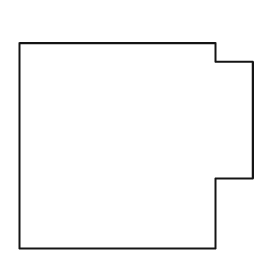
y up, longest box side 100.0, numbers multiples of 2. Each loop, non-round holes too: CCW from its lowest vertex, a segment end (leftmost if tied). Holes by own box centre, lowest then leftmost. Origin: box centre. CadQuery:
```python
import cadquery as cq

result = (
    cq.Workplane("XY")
    .moveTo(-50.0, -44.0)
    .lineTo(34.0, -44.0)
    .lineTo(34.0, -14.0)
    .lineTo(50.0, -14.0)
    .lineTo(50.0, 36.0)
    .lineTo(34.0, 36.0)
    .lineTo(34.0, 44.0)
    .lineTo(-50.0, 44.0)
    .close()
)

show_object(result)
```